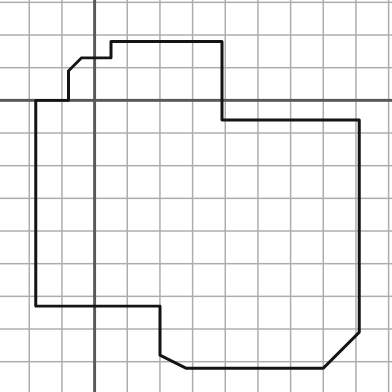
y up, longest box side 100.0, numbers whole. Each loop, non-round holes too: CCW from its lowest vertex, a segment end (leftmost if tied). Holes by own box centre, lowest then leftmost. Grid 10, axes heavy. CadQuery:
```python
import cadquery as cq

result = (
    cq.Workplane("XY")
    .moveTo(28.0, -82.0)
    .lineTo(70.0, -82.0)
    .lineTo(81.0, -71.0)
    .lineTo(81.0, -6.0)
    .lineTo(39.0, -6.0)
    .lineTo(39.0, 18.0)
    .lineTo(5.0, 18.0)
    .lineTo(5.0, 13.0)
    .lineTo(-4.0, 13.0)
    .lineTo(-8.0, 9.0)
    .lineTo(-8.0, 0.0)
    .lineTo(-18.0, 0.0)
    .lineTo(-18.0, -63.0)
    .lineTo(20.0, -63.0)
    .lineTo(20.0, -78.0)
    .close()
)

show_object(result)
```